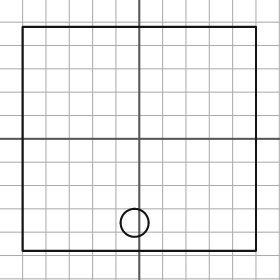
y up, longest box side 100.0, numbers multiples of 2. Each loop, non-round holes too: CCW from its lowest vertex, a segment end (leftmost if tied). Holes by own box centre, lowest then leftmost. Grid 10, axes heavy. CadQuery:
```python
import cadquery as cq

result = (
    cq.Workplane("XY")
    .moveTo(-50.0, -48.0)
    .lineTo(50.0, -48.0)
    .lineTo(50.0, 48.0)
    .lineTo(-50.0, 48.0)
    .close()
    .moveTo(-2.0, -36.0)
    .circle(6.0)
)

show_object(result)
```